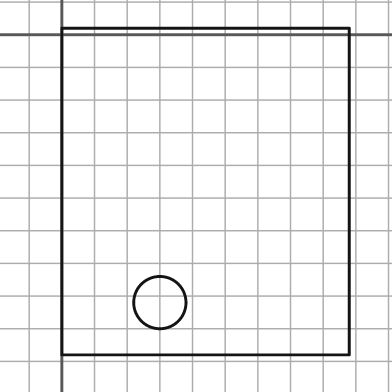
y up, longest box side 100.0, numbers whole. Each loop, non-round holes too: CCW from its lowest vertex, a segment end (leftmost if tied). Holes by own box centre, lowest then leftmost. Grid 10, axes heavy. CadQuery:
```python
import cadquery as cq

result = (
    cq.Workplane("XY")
    .moveTo(0.0, -98.0)
    .lineTo(88.0, -98.0)
    .lineTo(88.0, 2.0)
    .lineTo(0.0, 2.0)
    .close()
    .moveTo(30.0, -82.0)
    .circle(8.0)
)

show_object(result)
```